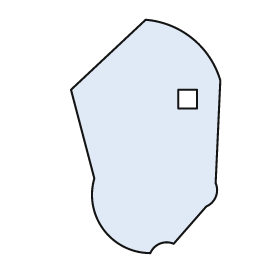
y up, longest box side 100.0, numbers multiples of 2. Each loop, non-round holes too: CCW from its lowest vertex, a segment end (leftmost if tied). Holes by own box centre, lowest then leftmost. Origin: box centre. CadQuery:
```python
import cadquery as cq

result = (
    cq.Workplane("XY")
    .moveTo(2.0, -50.0)
    .threePointArc((6.0, -46.0), (12.0, -46.0))
    .lineTo(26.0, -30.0)
    .threePointArc((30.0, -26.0), (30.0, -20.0))
    .lineTo(32.0, 24.0)
    .threePointArc((20.0, 42.0), (0.0, 50.0))
    .lineTo(-32.0, 20.0)
    .lineTo(-22.0, -18.0)
    .threePointArc((-18.0, -40.0), (2.0, -50.0))
    .close()
    .moveTo(14.0, 12.0)
    .lineTo(22.0, 12.0)
    .lineTo(22.0, 20.0)
    .lineTo(14.0, 20.0)
    .close()
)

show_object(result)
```